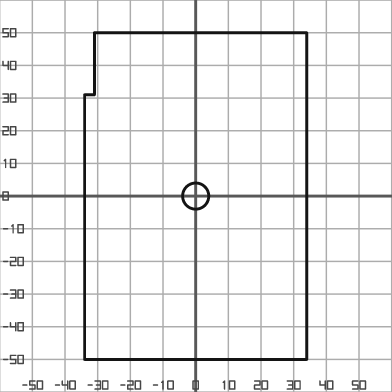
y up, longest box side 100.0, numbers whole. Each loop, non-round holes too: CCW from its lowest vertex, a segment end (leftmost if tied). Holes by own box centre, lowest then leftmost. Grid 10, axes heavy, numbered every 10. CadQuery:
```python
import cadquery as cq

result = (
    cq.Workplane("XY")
    .moveTo(-34.0, -50.0)
    .lineTo(34.0, -50.0)
    .lineTo(34.0, 50.0)
    .lineTo(-31.0, 50.0)
    .lineTo(-31.0, 31.0)
    .lineTo(-34.0, 31.0)
    .close()
    .moveTo(0.0, 0.0)
    .circle(4.0)
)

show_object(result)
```